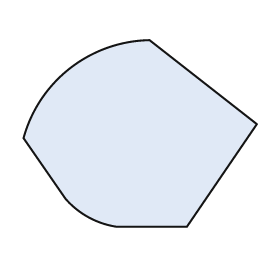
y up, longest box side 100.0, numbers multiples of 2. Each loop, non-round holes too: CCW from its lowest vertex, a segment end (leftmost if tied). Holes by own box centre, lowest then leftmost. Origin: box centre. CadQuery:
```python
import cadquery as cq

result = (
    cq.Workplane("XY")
    .moveTo(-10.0, -40.0)
    .lineTo(20.0, -40.0)
    .lineTo(50.0, 4.0)
    .lineTo(4.0, 40.0)
    .threePointArc((-30.0, 28.0), (-50.0, -2.0))
    .lineTo(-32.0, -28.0)
    .threePointArc((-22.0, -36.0), (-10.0, -40.0))
    .close()
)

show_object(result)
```